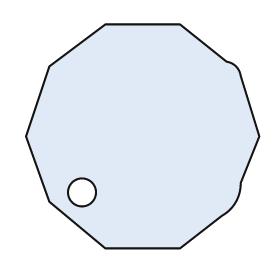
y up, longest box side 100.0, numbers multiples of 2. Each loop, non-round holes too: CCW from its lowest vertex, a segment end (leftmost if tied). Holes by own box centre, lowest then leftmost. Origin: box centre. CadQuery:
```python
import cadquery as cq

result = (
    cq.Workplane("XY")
    .moveTo(-16.0, -48.0)
    .lineTo(16.0, -48.0)
    .lineTo(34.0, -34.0)
    .threePointArc((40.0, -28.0), (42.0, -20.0))
    .lineTo(50.0, 0.0)
    .lineTo(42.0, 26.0)
    .threePointArc((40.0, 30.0), (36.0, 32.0))
    .lineTo(16.0, 48.0)
    .lineTo(-16.0, 48.0)
    .lineTo(-40.0, 30.0)
    .lineTo(-50.0, 0.0)
    .lineTo(-40.0, -28.0)
    .close()
    .moveTo(-26.0, -24.0)
    .circle(6.0)
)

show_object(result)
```